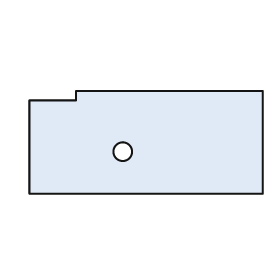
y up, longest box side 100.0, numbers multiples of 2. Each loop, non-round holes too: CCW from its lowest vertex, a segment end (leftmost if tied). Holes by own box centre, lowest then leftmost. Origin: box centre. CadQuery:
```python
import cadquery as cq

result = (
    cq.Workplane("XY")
    .moveTo(-50.0, -22.0)
    .lineTo(50.0, -22.0)
    .lineTo(50.0, 22.0)
    .lineTo(-30.0, 22.0)
    .lineTo(-30.0, 18.0)
    .lineTo(-50.0, 18.0)
    .close()
    .moveTo(-10.0, -4.0)
    .circle(4.0)
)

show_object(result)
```